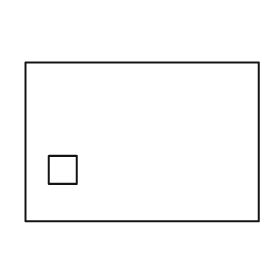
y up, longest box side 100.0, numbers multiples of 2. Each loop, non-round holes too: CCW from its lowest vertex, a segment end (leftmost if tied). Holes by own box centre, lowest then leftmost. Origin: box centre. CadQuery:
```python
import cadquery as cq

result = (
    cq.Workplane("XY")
    .moveTo(-50.0, -34.0)
    .lineTo(50.0, -34.0)
    .lineTo(50.0, 34.0)
    .lineTo(-50.0, 34.0)
    .close()
    .moveTo(-40.0, -18.0)
    .lineTo(-28.0, -18.0)
    .lineTo(-28.0, -6.0)
    .lineTo(-40.0, -6.0)
    .close()
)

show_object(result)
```